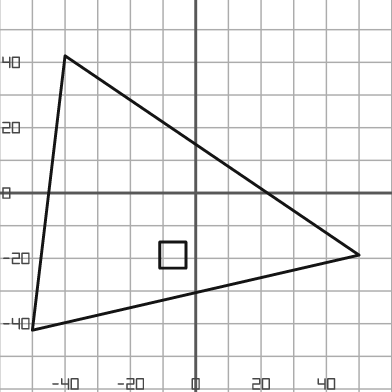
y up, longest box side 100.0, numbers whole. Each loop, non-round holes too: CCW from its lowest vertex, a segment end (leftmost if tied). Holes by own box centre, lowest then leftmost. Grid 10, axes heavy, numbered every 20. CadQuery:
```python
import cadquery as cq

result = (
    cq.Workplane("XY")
    .moveTo(-50.0, -42.0)
    .lineTo(50.0, -19.0)
    .lineTo(-40.0, 42.0)
    .close()
    .moveTo(-11.0, -23.0)
    .lineTo(-3.0, -23.0)
    .lineTo(-3.0, -15.0)
    .lineTo(-11.0, -15.0)
    .close()
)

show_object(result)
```